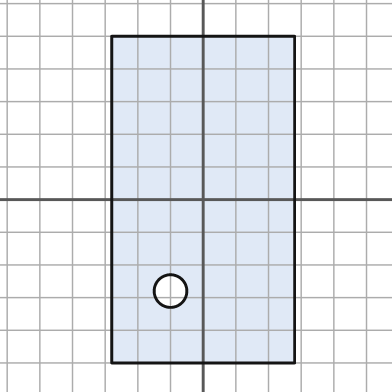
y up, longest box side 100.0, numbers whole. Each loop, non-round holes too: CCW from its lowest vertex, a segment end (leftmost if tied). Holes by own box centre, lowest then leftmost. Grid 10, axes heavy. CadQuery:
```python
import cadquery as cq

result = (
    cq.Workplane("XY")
    .moveTo(-28.0, -50.0)
    .lineTo(28.0, -50.0)
    .lineTo(28.0, 50.0)
    .lineTo(-28.0, 50.0)
    .close()
    .moveTo(-10.0, -28.0)
    .circle(5.0)
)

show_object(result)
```